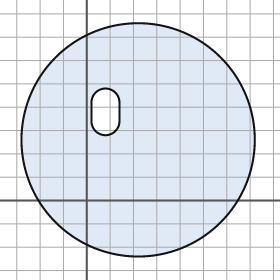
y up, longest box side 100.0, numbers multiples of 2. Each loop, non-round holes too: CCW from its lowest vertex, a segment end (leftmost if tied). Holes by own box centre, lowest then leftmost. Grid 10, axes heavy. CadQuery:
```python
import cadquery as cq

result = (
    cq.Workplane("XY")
    .moveTo(22.0, 26.0)
    .circle(50.0)
    .moveTo(2.0, 34.0)
    .threePointArc((8.0, 28.0), (14.0, 34.0))
    .lineTo(14.0, 42.0)
    .threePointArc((8.0, 48.0), (2.0, 42.0))
    .close()
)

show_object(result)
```